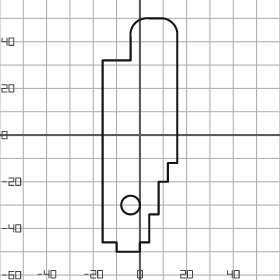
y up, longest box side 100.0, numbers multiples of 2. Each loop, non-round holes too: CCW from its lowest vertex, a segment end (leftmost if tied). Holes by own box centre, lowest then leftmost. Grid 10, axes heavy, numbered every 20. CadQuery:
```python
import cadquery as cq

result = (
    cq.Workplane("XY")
    .moveTo(-10.0, -50.0)
    .lineTo(0.0, -50.0)
    .lineTo(0.0, -46.0)
    .lineTo(4.0, -46.0)
    .lineTo(4.0, -34.0)
    .lineTo(8.0, -34.0)
    .lineTo(8.0, -20.0)
    .lineTo(12.0, -20.0)
    .lineTo(12.0, -12.0)
    .lineTo(16.0, -12.0)
    .lineTo(16.0, 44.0)
    .threePointArc((14.0, 48.0), (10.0, 50.0))
    .lineTo(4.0, 50.0)
    .threePointArc((-2.0, 48.0), (-4.0, 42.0))
    .lineTo(-4.0, 32.0)
    .lineTo(-16.0, 32.0)
    .lineTo(-16.0, -46.0)
    .lineTo(-10.0, -46.0)
    .close()
    .moveTo(-4.0, -30.0)
    .circle(4.0)
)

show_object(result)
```